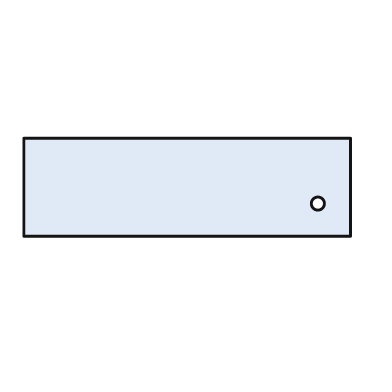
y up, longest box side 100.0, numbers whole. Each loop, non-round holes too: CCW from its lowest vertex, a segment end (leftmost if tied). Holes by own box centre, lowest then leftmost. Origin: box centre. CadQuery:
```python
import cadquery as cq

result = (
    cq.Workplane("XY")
    .moveTo(-50.0, -15.0)
    .lineTo(50.0, -15.0)
    .lineTo(50.0, 15.0)
    .lineTo(-50.0, 15.0)
    .close()
    .moveTo(40.0, -5.0)
    .circle(2.0)
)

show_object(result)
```